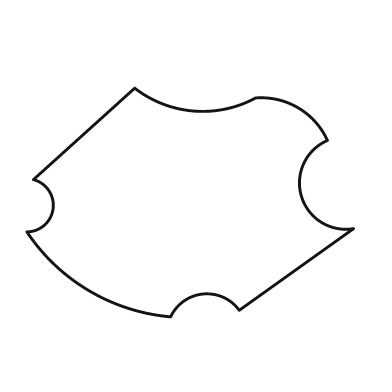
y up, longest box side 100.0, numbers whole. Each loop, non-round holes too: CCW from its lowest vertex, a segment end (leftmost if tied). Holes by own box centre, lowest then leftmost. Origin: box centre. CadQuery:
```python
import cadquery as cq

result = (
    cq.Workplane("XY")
    .moveTo(-6.0, -35.0)
    .threePointArc((4.0, -28.0), (15.0, -33.0))
    .lineTo(50.0, -8.0)
    .threePointArc((34.0, 2.0), (42.0, 19.0))
    .threePointArc((33.0, 29.0), (20.0, 32.0))
    .threePointArc((1.0, 28.0), (-17.0, 35.0))
    .lineTo(-48.0, 7.0)
    .threePointArc((-42.0, -2.0), (-50.0, -9.0))
    .threePointArc((-31.0, -27.0), (-6.0, -35.0))
    .close()
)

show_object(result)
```